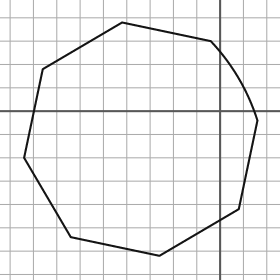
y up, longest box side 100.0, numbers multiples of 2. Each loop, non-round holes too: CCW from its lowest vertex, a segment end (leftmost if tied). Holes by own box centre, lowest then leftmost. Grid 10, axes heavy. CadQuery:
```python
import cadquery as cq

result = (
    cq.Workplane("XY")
    .moveTo(-26.0, -62.0)
    .lineTo(8.0, -42.0)
    .lineTo(16.0, -4.0)
    .threePointArc((8.0, 14.0), (-4.0, 30.0))
    .lineTo(-42.0, 38.0)
    .lineTo(-76.0, 18.0)
    .lineTo(-84.0, -20.0)
    .lineTo(-64.0, -54.0)
    .close()
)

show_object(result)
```